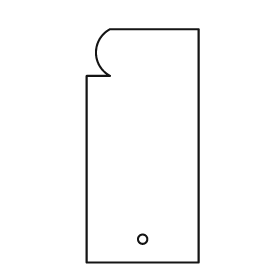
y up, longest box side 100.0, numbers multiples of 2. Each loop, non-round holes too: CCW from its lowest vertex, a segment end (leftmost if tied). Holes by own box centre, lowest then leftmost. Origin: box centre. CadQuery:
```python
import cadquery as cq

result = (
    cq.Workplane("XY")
    .moveTo(-24.0, -50.0)
    .lineTo(24.0, -50.0)
    .lineTo(24.0, 50.0)
    .lineTo(-14.0, 50.0)
    .threePointArc((-20.0, 40.0), (-14.0, 30.0))
    .lineTo(-24.0, 30.0)
    .close()
    .moveTo(0.0, -40.0)
    .circle(2.0)
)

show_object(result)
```